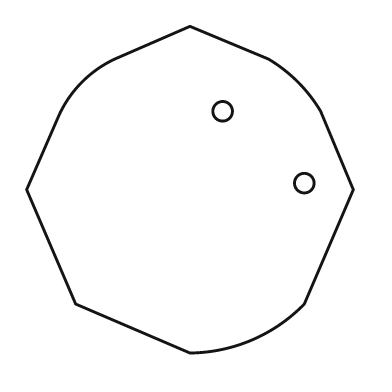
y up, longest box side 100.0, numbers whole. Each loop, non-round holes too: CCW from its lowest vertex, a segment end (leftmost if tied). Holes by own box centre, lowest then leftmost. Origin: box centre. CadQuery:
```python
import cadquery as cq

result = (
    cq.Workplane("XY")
    .moveTo(0.0, -50.0)
    .threePointArc((19.0, -46.0), (35.0, -35.0))
    .lineTo(50.0, 0.0)
    .lineTo(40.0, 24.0)
    .threePointArc((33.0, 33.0), (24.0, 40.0))
    .lineTo(0.0, 50.0)
    .lineTo(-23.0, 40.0)
    .threePointArc((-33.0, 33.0), (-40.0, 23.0))
    .lineTo(-50.0, 0.0)
    .lineTo(-35.0, -35.0)
    .close()
    .moveTo(35.0, 2.0)
    .circle(3.0)
    .moveTo(10.0, 24.0)
    .circle(3.0)
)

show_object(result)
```